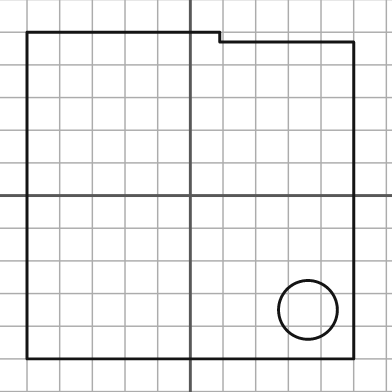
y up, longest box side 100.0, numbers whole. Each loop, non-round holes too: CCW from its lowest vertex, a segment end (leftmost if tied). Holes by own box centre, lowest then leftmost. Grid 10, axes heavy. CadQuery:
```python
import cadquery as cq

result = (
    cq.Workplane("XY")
    .moveTo(-50.0, -50.0)
    .lineTo(50.0, -50.0)
    .lineTo(50.0, 47.0)
    .lineTo(9.0, 47.0)
    .lineTo(9.0, 50.0)
    .lineTo(-50.0, 50.0)
    .close()
    .moveTo(36.0, -35.0)
    .circle(9.0)
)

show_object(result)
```